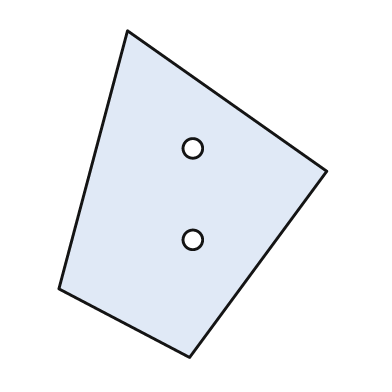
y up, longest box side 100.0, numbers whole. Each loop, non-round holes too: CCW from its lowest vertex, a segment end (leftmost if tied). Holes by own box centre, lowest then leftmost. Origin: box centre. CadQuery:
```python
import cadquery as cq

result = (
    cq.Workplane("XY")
    .moveTo(-1.0, -50.0)
    .lineTo(41.0, 7.0)
    .lineTo(-20.0, 50.0)
    .lineTo(-41.0, -29.0)
    .close()
    .moveTo(0.0, -14.0)
    .circle(3.0)
    .moveTo(0.0, 14.0)
    .circle(3.0)
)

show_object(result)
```